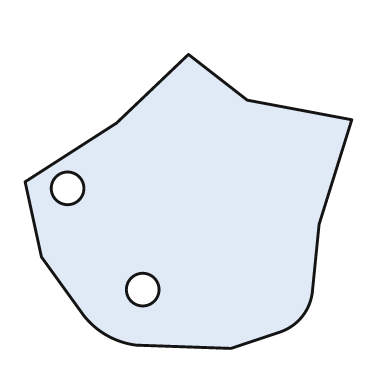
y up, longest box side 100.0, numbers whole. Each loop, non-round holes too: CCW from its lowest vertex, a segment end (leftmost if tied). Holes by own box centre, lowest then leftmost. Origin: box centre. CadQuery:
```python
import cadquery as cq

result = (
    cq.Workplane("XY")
    .moveTo(13.0, -45.0)
    .lineTo(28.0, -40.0)
    .threePointArc((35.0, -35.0), (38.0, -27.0))
    .lineTo(40.0, -7.0)
    .lineTo(50.0, 25.0)
    .lineTo(18.0, 31.0)
    .lineTo(0.0, 45.0)
    .lineTo(-22.0, 24.0)
    .lineTo(-50.0, 6.0)
    .lineTo(-45.0, -17.0)
    .lineTo(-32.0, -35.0)
    .threePointArc((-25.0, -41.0), (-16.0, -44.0))
    .close()
    .moveTo(-14.0, -27.0)
    .circle(5.0)
    .moveTo(-37.0, 4.0)
    .circle(5.0)
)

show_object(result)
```